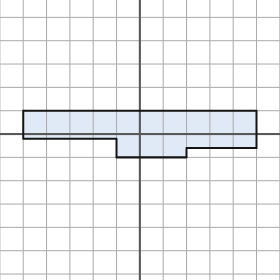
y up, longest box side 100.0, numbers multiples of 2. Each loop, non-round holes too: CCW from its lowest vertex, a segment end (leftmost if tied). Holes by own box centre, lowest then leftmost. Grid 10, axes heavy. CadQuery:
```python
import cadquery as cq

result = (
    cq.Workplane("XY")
    .moveTo(-10.0, -10.0)
    .lineTo(20.0, -10.0)
    .lineTo(20.0, -6.0)
    .lineTo(50.0, -6.0)
    .lineTo(50.0, 10.0)
    .lineTo(-50.0, 10.0)
    .lineTo(-50.0, -2.0)
    .lineTo(-10.0, -2.0)
    .close()
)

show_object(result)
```